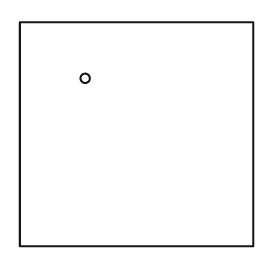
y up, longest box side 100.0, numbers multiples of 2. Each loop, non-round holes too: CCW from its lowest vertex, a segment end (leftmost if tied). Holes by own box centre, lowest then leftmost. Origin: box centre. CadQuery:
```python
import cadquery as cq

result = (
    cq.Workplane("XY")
    .moveTo(-50.0, -48.0)
    .lineTo(50.0, -48.0)
    .lineTo(50.0, 48.0)
    .lineTo(-50.0, 48.0)
    .close()
    .moveTo(-22.0, 24.0)
    .circle(2.0)
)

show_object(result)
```